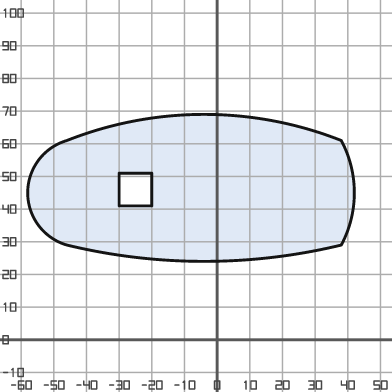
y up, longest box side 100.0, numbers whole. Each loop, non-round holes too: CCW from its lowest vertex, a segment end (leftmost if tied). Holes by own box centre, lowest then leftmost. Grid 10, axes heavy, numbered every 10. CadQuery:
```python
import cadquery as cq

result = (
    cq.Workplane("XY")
    .moveTo(-46.0, 29.0)
    .threePointArc((-4.0, 24.0), (38.0, 29.0))
    .threePointArc((42.0, 45.0), (38.0, 61.0))
    .threePointArc((-4.0, 69.0), (-46.0, 61.0))
    .threePointArc((-58.0, 45.0), (-46.0, 29.0))
    .close()
    .moveTo(-30.0, 41.0)
    .lineTo(-20.0, 41.0)
    .lineTo(-20.0, 51.0)
    .lineTo(-30.0, 51.0)
    .close()
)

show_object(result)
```